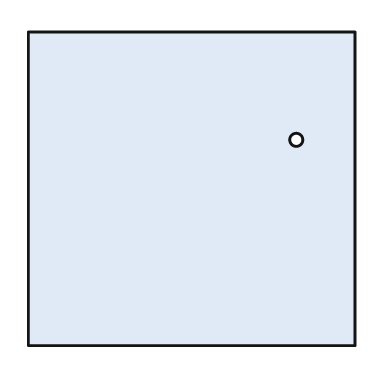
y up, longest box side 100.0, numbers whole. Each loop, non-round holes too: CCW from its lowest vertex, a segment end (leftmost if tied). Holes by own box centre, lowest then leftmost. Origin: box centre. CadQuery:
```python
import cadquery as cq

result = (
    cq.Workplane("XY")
    .moveTo(-50.0, -48.0)
    .lineTo(50.0, -48.0)
    .lineTo(50.0, 48.0)
    .lineTo(-50.0, 48.0)
    .close()
    .moveTo(32.0, 15.0)
    .circle(2.0)
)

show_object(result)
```